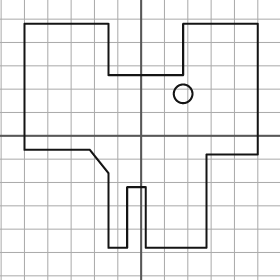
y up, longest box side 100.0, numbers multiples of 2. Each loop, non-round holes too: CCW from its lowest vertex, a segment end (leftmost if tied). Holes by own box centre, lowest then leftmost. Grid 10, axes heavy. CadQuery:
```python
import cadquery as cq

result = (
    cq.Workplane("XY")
    .moveTo(-14.0, -48.0)
    .lineTo(-6.0, -48.0)
    .lineTo(-6.0, -22.0)
    .lineTo(2.0, -22.0)
    .lineTo(2.0, -48.0)
    .lineTo(28.0, -48.0)
    .lineTo(28.0, -8.0)
    .lineTo(50.0, -8.0)
    .lineTo(50.0, 48.0)
    .lineTo(18.0, 48.0)
    .lineTo(18.0, 26.0)
    .lineTo(-14.0, 26.0)
    .lineTo(-14.0, 48.0)
    .lineTo(-50.0, 48.0)
    .lineTo(-50.0, -6.0)
    .lineTo(-22.0, -6.0)
    .lineTo(-14.0, -16.0)
    .close()
    .moveTo(18.0, 18.0)
    .circle(4.0)
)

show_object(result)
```